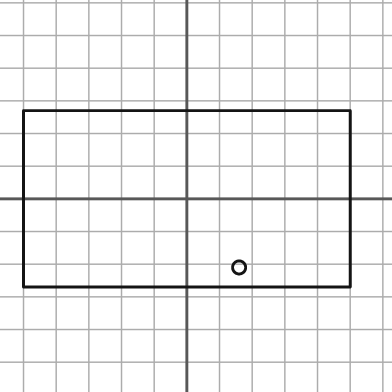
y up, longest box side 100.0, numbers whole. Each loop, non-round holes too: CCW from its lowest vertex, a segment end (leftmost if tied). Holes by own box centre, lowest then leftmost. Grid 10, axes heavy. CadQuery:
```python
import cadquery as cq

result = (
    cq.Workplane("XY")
    .moveTo(-50.0, -27.0)
    .lineTo(50.0, -27.0)
    .lineTo(50.0, 27.0)
    .lineTo(-50.0, 27.0)
    .close()
    .moveTo(16.0, -21.0)
    .circle(2.0)
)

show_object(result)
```